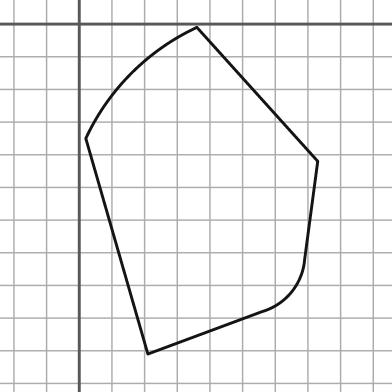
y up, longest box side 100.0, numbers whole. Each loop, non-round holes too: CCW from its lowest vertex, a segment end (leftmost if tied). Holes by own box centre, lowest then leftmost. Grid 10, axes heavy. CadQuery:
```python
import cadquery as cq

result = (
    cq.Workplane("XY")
    .moveTo(21.0, -101.0)
    .lineTo(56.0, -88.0)
    .threePointArc((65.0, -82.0), (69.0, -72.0))
    .lineTo(73.0, -42.0)
    .lineTo(36.0, -1.0)
    .threePointArc((16.0, -15.0), (2.0, -35.0))
    .close()
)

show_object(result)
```